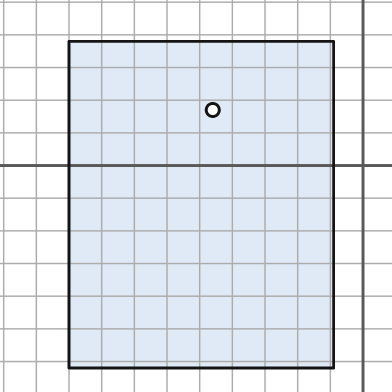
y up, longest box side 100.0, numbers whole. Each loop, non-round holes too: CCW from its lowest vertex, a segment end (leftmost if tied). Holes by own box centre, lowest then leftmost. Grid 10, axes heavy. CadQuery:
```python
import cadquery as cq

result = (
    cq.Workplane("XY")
    .moveTo(-90.0, -62.0)
    .lineTo(-9.0, -62.0)
    .lineTo(-9.0, 38.0)
    .lineTo(-90.0, 38.0)
    .close()
    .moveTo(-46.0, 17.0)
    .circle(2.0)
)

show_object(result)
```